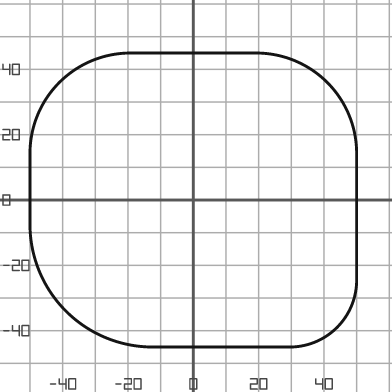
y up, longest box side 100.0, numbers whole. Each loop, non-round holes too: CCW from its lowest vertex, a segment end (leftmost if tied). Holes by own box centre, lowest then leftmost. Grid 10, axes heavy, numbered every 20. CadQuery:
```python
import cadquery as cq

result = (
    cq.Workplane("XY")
    .moveTo(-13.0, -45.0)
    .lineTo(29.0, -45.0)
    .threePointArc((44.0, -39.0), (50.0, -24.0))
    .lineTo(50.0, 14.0)
    .threePointArc((41.0, 36.0), (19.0, 45.0))
    .lineTo(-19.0, 45.0)
    .threePointArc((-41.0, 36.0), (-50.0, 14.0))
    .lineTo(-50.0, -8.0)
    .threePointArc((-39.0, -34.0), (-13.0, -45.0))
    .close()
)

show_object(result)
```